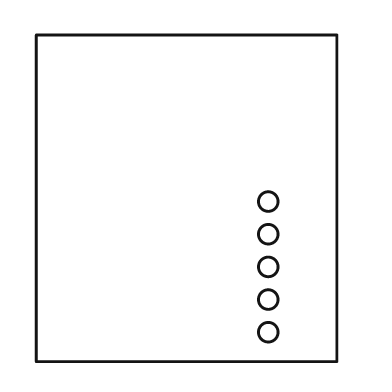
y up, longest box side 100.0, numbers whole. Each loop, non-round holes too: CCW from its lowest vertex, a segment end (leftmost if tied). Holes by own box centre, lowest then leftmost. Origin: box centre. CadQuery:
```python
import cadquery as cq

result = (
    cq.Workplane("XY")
    .moveTo(-46.0, -50.0)
    .lineTo(46.0, -50.0)
    .lineTo(46.0, 50.0)
    .lineTo(-46.0, 50.0)
    .close()
    .moveTo(25.0, -41.0)
    .circle(3.0)
    .moveTo(25.0, -31.0)
    .circle(3.0)
    .moveTo(25.0, -21.0)
    .circle(3.0)
    .moveTo(25.0, -11.0)
    .circle(3.0)
    .moveTo(25.0, -1.0)
    .circle(3.0)
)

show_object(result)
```